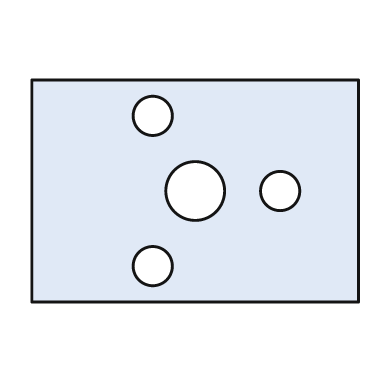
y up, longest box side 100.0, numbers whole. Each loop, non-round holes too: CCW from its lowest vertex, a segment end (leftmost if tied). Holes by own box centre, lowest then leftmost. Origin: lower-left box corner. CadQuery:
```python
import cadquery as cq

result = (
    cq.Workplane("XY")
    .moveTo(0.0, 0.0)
    .lineTo(100.0, 0.0)
    .lineTo(100.0, 68.0)
    .lineTo(0.0, 68.0)
    .close()
    .moveTo(37.0, 11.0)
    .circle(6.0)
    .moveTo(50.0, 34.0)
    .circle(9.0)
    .moveTo(76.0, 34.0)
    .circle(6.0)
    .moveTo(37.0, 57.0)
    .circle(6.0)
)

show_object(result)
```